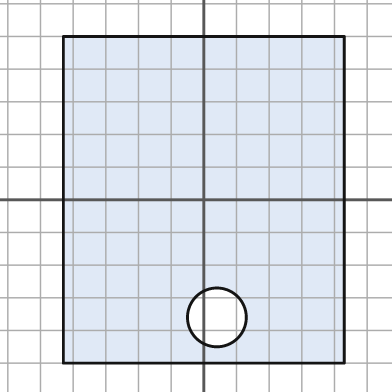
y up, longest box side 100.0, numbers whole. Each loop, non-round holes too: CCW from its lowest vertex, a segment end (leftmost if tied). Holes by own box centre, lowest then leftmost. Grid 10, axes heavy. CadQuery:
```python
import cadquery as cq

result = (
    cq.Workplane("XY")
    .moveTo(-43.0, -50.0)
    .lineTo(43.0, -50.0)
    .lineTo(43.0, 50.0)
    .lineTo(-43.0, 50.0)
    .close()
    .moveTo(4.0, -36.0)
    .circle(9.0)
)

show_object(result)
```